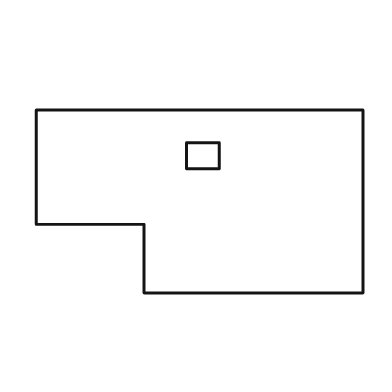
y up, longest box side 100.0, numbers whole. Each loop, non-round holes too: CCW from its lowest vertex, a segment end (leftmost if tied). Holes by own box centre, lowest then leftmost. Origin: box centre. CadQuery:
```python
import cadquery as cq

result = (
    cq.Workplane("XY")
    .moveTo(-17.0, -28.0)
    .lineTo(50.0, -28.0)
    .lineTo(50.0, 28.0)
    .lineTo(-50.0, 28.0)
    .lineTo(-50.0, -7.0)
    .lineTo(-17.0, -7.0)
    .close()
    .moveTo(-4.0, 10.0)
    .lineTo(6.0, 10.0)
    .lineTo(6.0, 18.0)
    .lineTo(-4.0, 18.0)
    .close()
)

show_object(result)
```